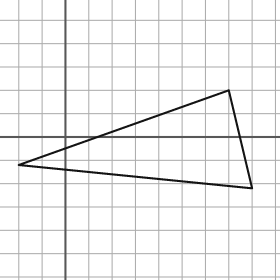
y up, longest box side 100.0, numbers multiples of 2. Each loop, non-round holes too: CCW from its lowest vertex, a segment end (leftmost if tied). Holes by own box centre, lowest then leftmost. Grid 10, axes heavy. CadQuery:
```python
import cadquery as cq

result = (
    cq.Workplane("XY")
    .moveTo(80.0, -22.0)
    .lineTo(70.0, 20.0)
    .lineTo(-20.0, -12.0)
    .close()
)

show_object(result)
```